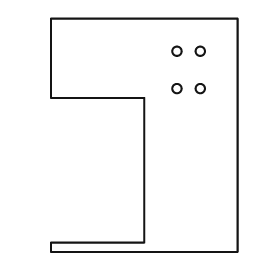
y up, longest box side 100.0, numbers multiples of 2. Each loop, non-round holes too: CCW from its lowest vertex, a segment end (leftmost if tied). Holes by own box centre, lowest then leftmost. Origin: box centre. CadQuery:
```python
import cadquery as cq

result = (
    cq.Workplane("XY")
    .moveTo(-40.0, -50.0)
    .lineTo(40.0, -50.0)
    .lineTo(40.0, 50.0)
    .lineTo(-40.0, 50.0)
    .lineTo(-40.0, 16.0)
    .lineTo(0.0, 16.0)
    .lineTo(0.0, -46.0)
    .lineTo(-40.0, -46.0)
    .close()
    .moveTo(14.0, 20.0)
    .circle(2.0)
    .moveTo(24.0, 20.0)
    .circle(2.0)
    .moveTo(14.0, 36.0)
    .circle(2.0)
    .moveTo(24.0, 36.0)
    .circle(2.0)
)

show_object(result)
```